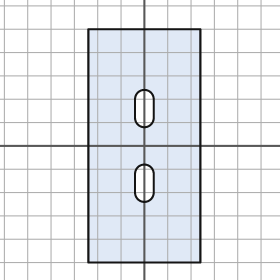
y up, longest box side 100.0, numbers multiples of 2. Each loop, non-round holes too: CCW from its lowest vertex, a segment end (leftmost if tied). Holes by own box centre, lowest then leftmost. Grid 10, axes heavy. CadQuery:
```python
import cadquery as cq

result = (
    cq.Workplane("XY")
    .moveTo(-24.0, -50.0)
    .lineTo(24.0, -50.0)
    .lineTo(24.0, 50.0)
    .lineTo(-24.0, 50.0)
    .close()
    .moveTo(-4.0, -20.0)
    .threePointArc((0.0, -24.0), (4.0, -20.0))
    .lineTo(4.0, -12.0)
    .threePointArc((0.0, -8.0), (-4.0, -12.0))
    .close()
    .moveTo(-4.0, 12.0)
    .threePointArc((0.0, 8.0), (4.0, 12.0))
    .lineTo(4.0, 20.0)
    .threePointArc((0.0, 24.0), (-4.0, 20.0))
    .close()
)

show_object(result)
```